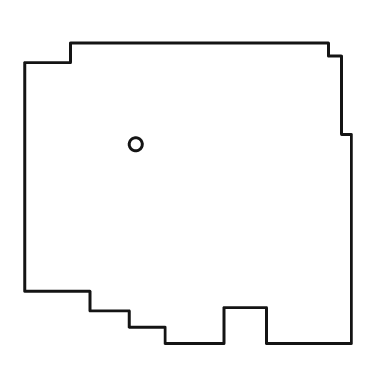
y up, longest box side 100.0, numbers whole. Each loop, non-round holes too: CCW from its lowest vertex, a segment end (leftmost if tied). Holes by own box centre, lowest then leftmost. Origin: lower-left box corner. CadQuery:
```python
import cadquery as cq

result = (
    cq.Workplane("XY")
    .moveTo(43.0, 0.0)
    .lineTo(61.0, 0.0)
    .lineTo(61.0, 11.0)
    .lineTo(74.0, 11.0)
    .lineTo(74.0, 0.0)
    .lineTo(100.0, 0.0)
    .lineTo(100.0, 64.0)
    .lineTo(97.0, 64.0)
    .lineTo(97.0, 88.0)
    .lineTo(93.0, 88.0)
    .lineTo(93.0, 92.0)
    .lineTo(14.0, 92.0)
    .lineTo(14.0, 86.0)
    .lineTo(0.0, 86.0)
    .lineTo(0.0, 16.0)
    .lineTo(20.0, 16.0)
    .lineTo(20.0, 10.0)
    .lineTo(32.0, 10.0)
    .lineTo(32.0, 5.0)
    .lineTo(43.0, 5.0)
    .close()
    .moveTo(34.0, 61.0)
    .circle(2.0)
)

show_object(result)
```